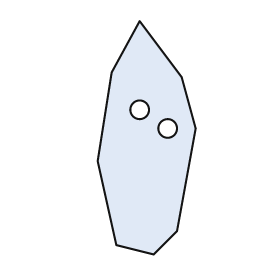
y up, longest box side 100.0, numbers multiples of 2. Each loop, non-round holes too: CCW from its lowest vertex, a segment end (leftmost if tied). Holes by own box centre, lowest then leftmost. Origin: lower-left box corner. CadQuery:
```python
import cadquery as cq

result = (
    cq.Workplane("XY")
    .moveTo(24.0, 0.0)
    .lineTo(34.0, 10.0)
    .lineTo(42.0, 54.0)
    .lineTo(36.0, 76.0)
    .lineTo(18.0, 100.0)
    .lineTo(6.0, 78.0)
    .lineTo(0.0, 40.0)
    .lineTo(8.0, 4.0)
    .close()
    .moveTo(30.0, 54.0)
    .circle(4.0)
    .moveTo(18.0, 62.0)
    .circle(4.0)
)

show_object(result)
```